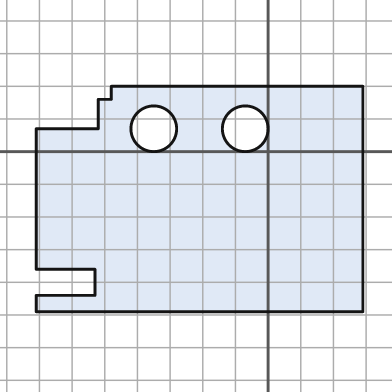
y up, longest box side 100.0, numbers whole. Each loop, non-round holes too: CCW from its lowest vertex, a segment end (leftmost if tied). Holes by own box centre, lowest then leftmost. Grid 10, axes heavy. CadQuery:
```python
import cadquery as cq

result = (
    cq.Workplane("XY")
    .moveTo(-71.0, -49.0)
    .lineTo(29.0, -49.0)
    .lineTo(29.0, 20.0)
    .lineTo(-48.0, 20.0)
    .lineTo(-48.0, 16.0)
    .lineTo(-52.0, 16.0)
    .lineTo(-52.0, 7.0)
    .lineTo(-71.0, 7.0)
    .lineTo(-71.0, -36.0)
    .lineTo(-53.0, -36.0)
    .lineTo(-53.0, -44.0)
    .lineTo(-71.0, -44.0)
    .close()
    .moveTo(-35.0, 7.0)
    .circle(7.0)
    .moveTo(-7.0, 7.0)
    .circle(7.0)
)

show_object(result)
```